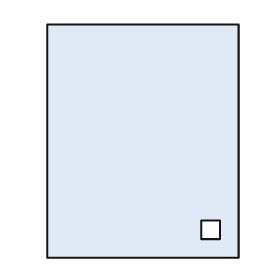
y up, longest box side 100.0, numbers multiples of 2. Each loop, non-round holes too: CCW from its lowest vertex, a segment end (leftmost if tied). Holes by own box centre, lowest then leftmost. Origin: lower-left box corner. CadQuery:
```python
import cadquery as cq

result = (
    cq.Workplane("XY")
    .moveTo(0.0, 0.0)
    .lineTo(82.0, 0.0)
    .lineTo(82.0, 100.0)
    .lineTo(0.0, 100.0)
    .close()
    .moveTo(66.0, 8.0)
    .lineTo(74.0, 8.0)
    .lineTo(74.0, 16.0)
    .lineTo(66.0, 16.0)
    .close()
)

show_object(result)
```